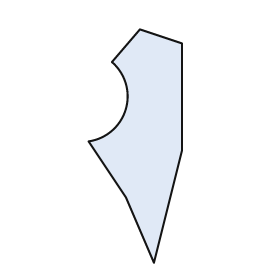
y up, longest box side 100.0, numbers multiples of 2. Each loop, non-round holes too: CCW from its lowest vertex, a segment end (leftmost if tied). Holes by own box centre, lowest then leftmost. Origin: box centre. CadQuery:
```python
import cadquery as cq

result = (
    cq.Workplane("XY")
    .moveTo(8.0, -50.0)
    .lineTo(20.0, -2.0)
    .lineTo(20.0, 44.0)
    .lineTo(2.0, 50.0)
    .lineTo(-10.0, 36.0)
    .threePointArc((-4.0, 16.0), (-20.0, 2.0))
    .lineTo(-4.0, -22.0)
    .close()
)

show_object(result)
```